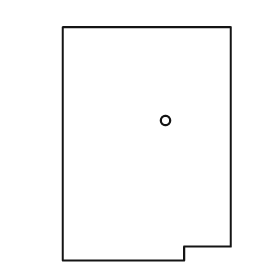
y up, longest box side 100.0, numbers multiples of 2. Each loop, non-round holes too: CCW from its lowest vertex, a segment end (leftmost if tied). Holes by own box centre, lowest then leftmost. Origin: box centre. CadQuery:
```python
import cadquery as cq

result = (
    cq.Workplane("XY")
    .moveTo(-36.0, -50.0)
    .lineTo(16.0, -50.0)
    .lineTo(16.0, -44.0)
    .lineTo(36.0, -44.0)
    .lineTo(36.0, 50.0)
    .lineTo(-36.0, 50.0)
    .close()
    .moveTo(8.0, 10.0)
    .circle(2.0)
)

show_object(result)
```